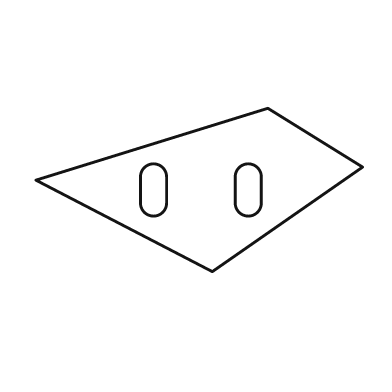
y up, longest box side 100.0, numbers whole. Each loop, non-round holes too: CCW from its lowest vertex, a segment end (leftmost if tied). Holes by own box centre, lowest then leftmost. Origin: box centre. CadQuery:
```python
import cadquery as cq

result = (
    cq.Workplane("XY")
    .moveTo(4.0, -25.0)
    .lineTo(50.0, 7.0)
    .lineTo(21.0, 25.0)
    .lineTo(-50.0, 3.0)
    .close()
    .moveTo(-18.0, -4.0)
    .threePointArc((-14.0, -8.0), (-10.0, -4.0))
    .lineTo(-10.0, 4.0)
    .threePointArc((-14.0, 8.0), (-18.0, 4.0))
    .close()
    .moveTo(11.0, -4.0)
    .threePointArc((15.0, -8.0), (19.0, -4.0))
    .lineTo(19.0, 4.0)
    .threePointArc((15.0, 8.0), (11.0, 4.0))
    .close()
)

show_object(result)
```